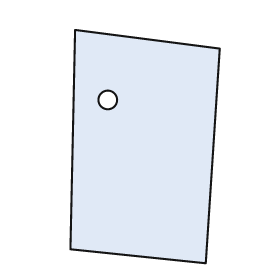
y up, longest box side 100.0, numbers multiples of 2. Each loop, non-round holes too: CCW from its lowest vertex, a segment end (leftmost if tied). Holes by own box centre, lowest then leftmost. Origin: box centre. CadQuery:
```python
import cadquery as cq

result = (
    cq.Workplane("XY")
    .moveTo(26.0, -50.0)
    .lineTo(32.0, 42.0)
    .lineTo(-30.0, 50.0)
    .lineTo(-32.0, -44.0)
    .close()
    .moveTo(-16.0, 20.0)
    .circle(4.0)
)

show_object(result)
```